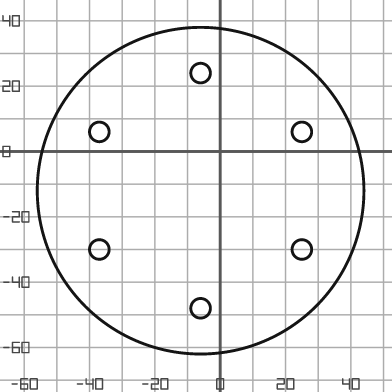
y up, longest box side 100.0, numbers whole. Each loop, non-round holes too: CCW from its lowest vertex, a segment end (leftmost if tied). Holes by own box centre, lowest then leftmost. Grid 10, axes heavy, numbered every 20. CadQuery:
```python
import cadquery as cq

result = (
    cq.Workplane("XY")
    .moveTo(-6.0, -12.0)
    .circle(50.0)
    .moveTo(-6.0, -48.0)
    .circle(3.0)
    .moveTo(-37.0, -30.0)
    .circle(3.0)
    .moveTo(25.0, -30.0)
    .circle(3.0)
    .moveTo(-37.0, 6.0)
    .circle(3.0)
    .moveTo(25.0, 6.0)
    .circle(3.0)
    .moveTo(-6.0, 24.0)
    .circle(3.0)
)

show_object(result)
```